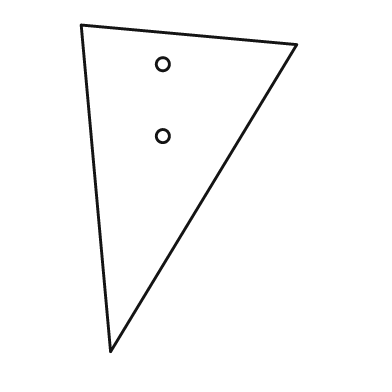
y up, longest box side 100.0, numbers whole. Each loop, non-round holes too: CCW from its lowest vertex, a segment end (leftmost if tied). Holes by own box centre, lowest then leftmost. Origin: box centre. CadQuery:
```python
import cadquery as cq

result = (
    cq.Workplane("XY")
    .moveTo(-24.0, -50.0)
    .lineTo(33.0, 44.0)
    .lineTo(-33.0, 50.0)
    .close()
    .moveTo(-8.0, 16.0)
    .circle(2.0)
    .moveTo(-8.0, 38.0)
    .circle(2.0)
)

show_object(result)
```